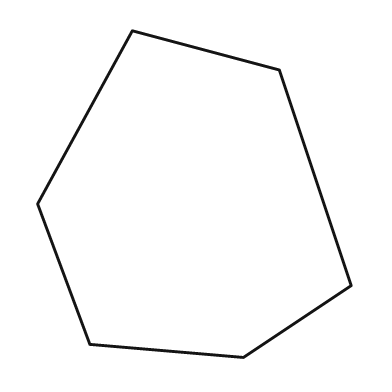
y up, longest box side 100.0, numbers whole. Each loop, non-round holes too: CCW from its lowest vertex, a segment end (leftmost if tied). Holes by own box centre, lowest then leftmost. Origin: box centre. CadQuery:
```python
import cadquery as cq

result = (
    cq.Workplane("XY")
    .moveTo(15.0, -50.0)
    .lineTo(48.0, -28.0)
    .lineTo(26.0, 38.0)
    .lineTo(-19.0, 50.0)
    .lineTo(-48.0, -3.0)
    .lineTo(-32.0, -46.0)
    .close()
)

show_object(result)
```